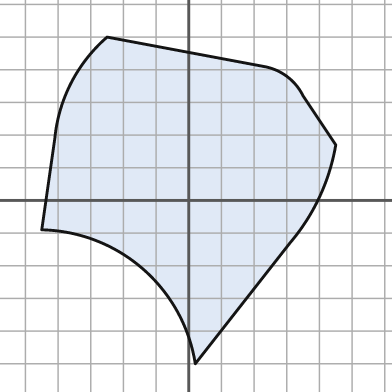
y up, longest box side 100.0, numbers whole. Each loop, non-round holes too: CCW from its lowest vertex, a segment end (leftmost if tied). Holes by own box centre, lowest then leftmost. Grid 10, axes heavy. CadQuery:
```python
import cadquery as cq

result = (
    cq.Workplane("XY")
    .moveTo(2.0, -50.0)
    .lineTo(31.0, -13.0)
    .threePointArc((40.0, 1.0), (45.0, 17.0))
    .lineTo(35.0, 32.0)
    .threePointArc((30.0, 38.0), (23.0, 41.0))
    .lineTo(-25.0, 50.0)
    .threePointArc((-36.0, 36.0), (-41.0, 19.0))
    .lineTo(-45.0, -9.0)
    .threePointArc((-14.0, -21.0), (2.0, -50.0))
    .close()
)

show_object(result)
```